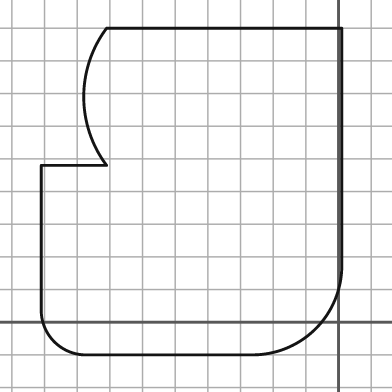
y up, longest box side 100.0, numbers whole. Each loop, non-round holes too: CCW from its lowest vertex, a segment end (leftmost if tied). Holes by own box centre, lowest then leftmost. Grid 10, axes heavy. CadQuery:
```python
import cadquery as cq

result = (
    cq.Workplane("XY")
    .moveTo(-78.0, -10.0)
    .lineTo(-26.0, -10.0)
    .threePointArc((-7.0, -2.0), (1.0, 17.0))
    .lineTo(1.0, 90.0)
    .lineTo(-71.0, 90.0)
    .threePointArc((-78.0, 69.0), (-71.0, 48.0))
    .lineTo(-91.0, 48.0)
    .lineTo(-91.0, 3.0)
    .threePointArc((-87.0, -6.0), (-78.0, -10.0))
    .close()
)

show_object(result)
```